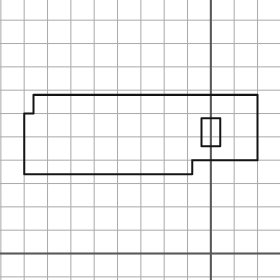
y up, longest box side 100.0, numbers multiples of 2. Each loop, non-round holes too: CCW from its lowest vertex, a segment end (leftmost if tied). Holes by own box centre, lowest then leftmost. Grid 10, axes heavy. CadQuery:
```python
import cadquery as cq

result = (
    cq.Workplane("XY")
    .moveTo(-80.0, 34.0)
    .lineTo(-8.0, 34.0)
    .lineTo(-8.0, 40.0)
    .lineTo(20.0, 40.0)
    .lineTo(20.0, 68.0)
    .lineTo(-76.0, 68.0)
    .lineTo(-76.0, 60.0)
    .lineTo(-80.0, 60.0)
    .close()
    .moveTo(-4.0, 46.0)
    .lineTo(4.0, 46.0)
    .lineTo(4.0, 58.0)
    .lineTo(-4.0, 58.0)
    .close()
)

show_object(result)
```